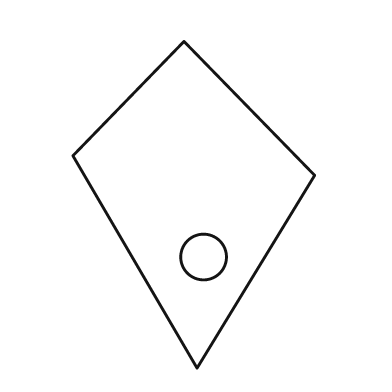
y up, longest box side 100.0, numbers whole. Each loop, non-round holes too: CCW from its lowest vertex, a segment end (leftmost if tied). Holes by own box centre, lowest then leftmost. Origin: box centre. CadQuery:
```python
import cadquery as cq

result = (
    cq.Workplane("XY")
    .moveTo(1.0, -50.0)
    .lineTo(37.0, 9.0)
    .lineTo(-3.0, 50.0)
    .lineTo(-37.0, 15.0)
    .close()
    .moveTo(3.0, -16.0)
    .circle(7.0)
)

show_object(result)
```